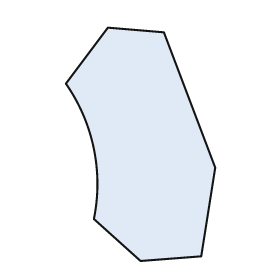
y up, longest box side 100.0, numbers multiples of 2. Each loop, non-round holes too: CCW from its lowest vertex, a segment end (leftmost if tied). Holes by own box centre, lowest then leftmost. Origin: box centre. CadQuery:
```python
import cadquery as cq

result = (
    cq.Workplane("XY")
    .moveTo(0.0, -50.0)
    .lineTo(26.0, -48.0)
    .lineTo(32.0, -10.0)
    .lineTo(10.0, 48.0)
    .lineTo(-14.0, 50.0)
    .lineTo(-32.0, 26.0)
    .threePointArc((-20.0, -2.0), (-20.0, -32.0))
    .close()
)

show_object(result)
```